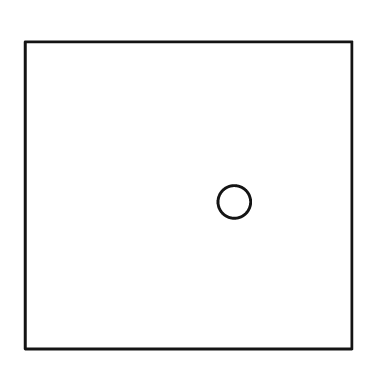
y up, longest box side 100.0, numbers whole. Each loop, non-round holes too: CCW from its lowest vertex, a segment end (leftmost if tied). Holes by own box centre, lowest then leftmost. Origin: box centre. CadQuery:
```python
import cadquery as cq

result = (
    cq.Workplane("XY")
    .moveTo(-50.0, -47.0)
    .lineTo(50.0, -47.0)
    .lineTo(50.0, 47.0)
    .lineTo(-50.0, 47.0)
    .close()
    .moveTo(14.0, -2.0)
    .circle(5.0)
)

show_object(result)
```